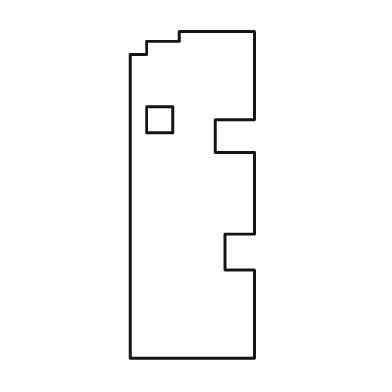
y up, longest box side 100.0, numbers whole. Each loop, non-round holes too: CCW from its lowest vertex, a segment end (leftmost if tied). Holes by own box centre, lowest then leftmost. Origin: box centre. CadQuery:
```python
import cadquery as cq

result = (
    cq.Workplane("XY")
    .moveTo(-19.0, -50.0)
    .lineTo(19.0, -50.0)
    .lineTo(19.0, -23.0)
    .lineTo(10.0, -23.0)
    .lineTo(10.0, -12.0)
    .lineTo(19.0, -12.0)
    .lineTo(19.0, 13.0)
    .lineTo(7.0, 13.0)
    .lineTo(7.0, 23.0)
    .lineTo(19.0, 23.0)
    .lineTo(19.0, 50.0)
    .lineTo(-4.0, 50.0)
    .lineTo(-4.0, 47.0)
    .lineTo(-14.0, 47.0)
    .lineTo(-14.0, 43.0)
    .lineTo(-19.0, 43.0)
    .close()
    .moveTo(-14.0, 19.0)
    .lineTo(-6.0, 19.0)
    .lineTo(-6.0, 27.0)
    .lineTo(-14.0, 27.0)
    .close()
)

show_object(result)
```